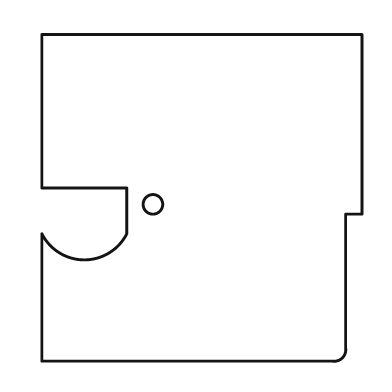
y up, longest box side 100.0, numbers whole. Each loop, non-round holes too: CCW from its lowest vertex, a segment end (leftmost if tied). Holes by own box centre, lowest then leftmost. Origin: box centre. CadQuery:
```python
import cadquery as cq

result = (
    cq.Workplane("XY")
    .moveTo(-49.0, -50.0)
    .lineTo(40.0, -50.0)
    .threePointArc((43.0, -49.0), (44.0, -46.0))
    .lineTo(44.0, -5.0)
    .lineTo(49.0, -5.0)
    .lineTo(49.0, 50.0)
    .lineTo(-49.0, 50.0)
    .lineTo(-49.0, 3.0)
    .lineTo(-23.0, 3.0)
    .lineTo(-23.0, -11.0)
    .threePointArc((-36.0, -19.0), (-49.0, -11.0))
    .close()
    .moveTo(-15.0, -2.0)
    .circle(3.0)
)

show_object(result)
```